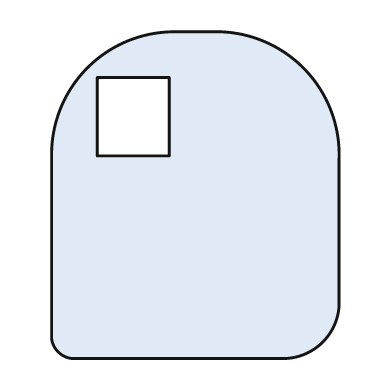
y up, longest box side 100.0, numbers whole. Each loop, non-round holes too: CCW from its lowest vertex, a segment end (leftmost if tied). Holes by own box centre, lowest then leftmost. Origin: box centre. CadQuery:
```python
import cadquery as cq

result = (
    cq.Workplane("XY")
    .moveTo(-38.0, -50.0)
    .lineTo(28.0, -50.0)
    .threePointArc((39.0, -45.0), (44.0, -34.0))
    .lineTo(44.0, 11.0)
    .threePointArc((33.0, 39.0), (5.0, 50.0))
    .lineTo(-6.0, 50.0)
    .threePointArc((-33.0, 39.0), (-44.0, 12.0))
    .lineTo(-44.0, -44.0)
    .threePointArc((-42.0, -48.0), (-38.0, -50.0))
    .close()
    .moveTo(-30.0, 12.0)
    .lineTo(-8.0, 12.0)
    .lineTo(-8.0, 36.0)
    .lineTo(-30.0, 36.0)
    .close()
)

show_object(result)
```